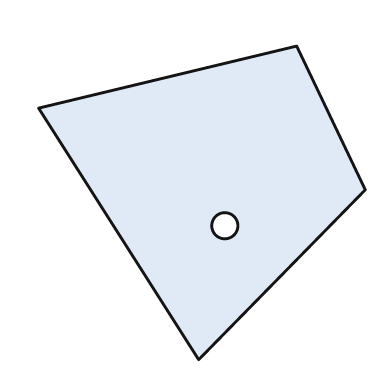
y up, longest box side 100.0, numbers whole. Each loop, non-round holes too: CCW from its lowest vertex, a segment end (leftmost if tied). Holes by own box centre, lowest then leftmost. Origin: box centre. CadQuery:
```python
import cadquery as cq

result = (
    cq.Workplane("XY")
    .moveTo(-1.0, -48.0)
    .lineTo(50.0, 4.0)
    .lineTo(29.0, 48.0)
    .lineTo(-50.0, 29.0)
    .close()
    .moveTo(7.0, -7.0)
    .circle(4.0)
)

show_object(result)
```